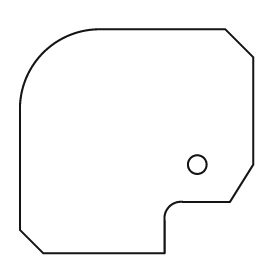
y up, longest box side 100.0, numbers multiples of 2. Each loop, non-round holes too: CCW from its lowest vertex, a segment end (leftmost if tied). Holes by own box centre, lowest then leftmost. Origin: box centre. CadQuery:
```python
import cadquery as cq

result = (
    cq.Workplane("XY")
    .moveTo(-40.0, -48.0)
    .lineTo(12.0, -48.0)
    .lineTo(12.0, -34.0)
    .threePointArc((14.0, -28.0), (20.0, -26.0))
    .lineTo(40.0, -26.0)
    .lineTo(50.0, -10.0)
    .lineTo(50.0, 36.0)
    .lineTo(38.0, 48.0)
    .lineTo(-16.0, 48.0)
    .threePointArc((-40.0, 38.0), (-50.0, 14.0))
    .lineTo(-50.0, -38.0)
    .close()
    .moveTo(26.0, -10.0)
    .circle(4.0)
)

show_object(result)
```